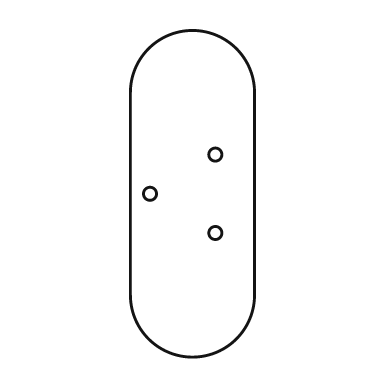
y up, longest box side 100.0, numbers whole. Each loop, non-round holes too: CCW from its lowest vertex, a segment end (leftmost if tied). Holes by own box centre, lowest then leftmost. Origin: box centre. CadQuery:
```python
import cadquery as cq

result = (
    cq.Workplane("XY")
    .moveTo(-19.0, -31.0)
    .threePointArc((0.0, -50.0), (19.0, -31.0))
    .lineTo(19.0, 31.0)
    .threePointArc((0.0, 50.0), (-19.0, 31.0))
    .close()
    .moveTo(7.0, -12.0)
    .circle(2.0)
    .moveTo(-13.0, 0.0)
    .circle(2.0)
    .moveTo(7.0, 12.0)
    .circle(2.0)
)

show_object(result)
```